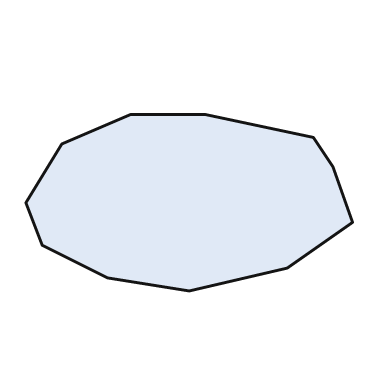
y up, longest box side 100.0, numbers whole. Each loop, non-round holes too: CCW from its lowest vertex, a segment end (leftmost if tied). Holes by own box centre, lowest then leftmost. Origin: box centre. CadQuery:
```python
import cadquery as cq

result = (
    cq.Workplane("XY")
    .moveTo(0.0, -27.0)
    .lineTo(30.0, -20.0)
    .lineTo(50.0, -6.0)
    .lineTo(44.0, 11.0)
    .lineTo(38.0, 20.0)
    .lineTo(5.0, 27.0)
    .lineTo(-18.0, 27.0)
    .lineTo(-39.0, 18.0)
    .lineTo(-50.0, 0.0)
    .lineTo(-45.0, -13.0)
    .lineTo(-25.0, -23.0)
    .close()
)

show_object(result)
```